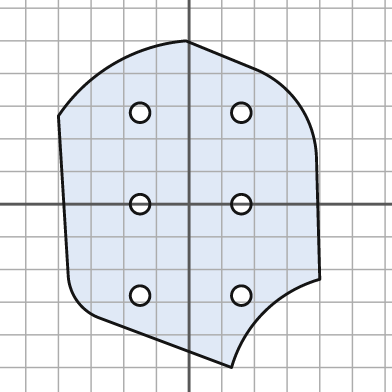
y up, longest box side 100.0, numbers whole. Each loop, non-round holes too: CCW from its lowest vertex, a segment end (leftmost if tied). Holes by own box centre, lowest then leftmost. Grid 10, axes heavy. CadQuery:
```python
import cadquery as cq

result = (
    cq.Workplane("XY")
    .moveTo(13.0, -50.0)
    .threePointArc((23.0, -33.0), (40.0, -23.0))
    .lineTo(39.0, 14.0)
    .threePointArc((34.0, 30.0), (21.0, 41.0))
    .lineTo(-1.0, 50.0)
    .threePointArc((-23.0, 43.0), (-40.0, 27.0))
    .lineTo(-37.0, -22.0)
    .threePointArc((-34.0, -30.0), (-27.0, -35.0))
    .close()
    .moveTo(-15.0, -28.0)
    .circle(3.0)
    .moveTo(16.0, -28.0)
    .circle(3.0)
    .moveTo(-15.0, 0.0)
    .circle(3.0)
    .moveTo(16.0, 0.0)
    .circle(3.0)
    .moveTo(-15.0, 28.0)
    .circle(3.0)
    .moveTo(16.0, 28.0)
    .circle(3.0)
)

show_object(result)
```